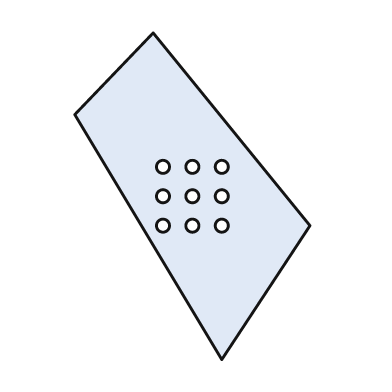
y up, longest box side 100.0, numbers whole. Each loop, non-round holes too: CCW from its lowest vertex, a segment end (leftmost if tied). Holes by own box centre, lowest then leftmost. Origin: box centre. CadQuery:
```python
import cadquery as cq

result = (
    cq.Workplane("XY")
    .moveTo(9.0, -50.0)
    .lineTo(36.0, -9.0)
    .lineTo(-12.0, 50.0)
    .lineTo(-36.0, 25.0)
    .close()
    .moveTo(-9.0, -9.0)
    .circle(2.0)
    .moveTo(0.0, -9.0)
    .circle(2.0)
    .moveTo(9.0, -9.0)
    .circle(2.0)
    .moveTo(-9.0, 0.0)
    .circle(2.0)
    .moveTo(0.0, 0.0)
    .circle(2.0)
    .moveTo(9.0, 0.0)
    .circle(2.0)
    .moveTo(-9.0, 9.0)
    .circle(2.0)
    .moveTo(0.0, 9.0)
    .circle(2.0)
    .moveTo(9.0, 9.0)
    .circle(2.0)
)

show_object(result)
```